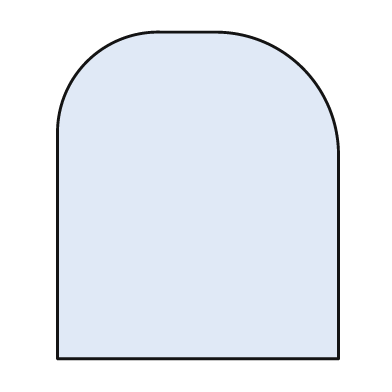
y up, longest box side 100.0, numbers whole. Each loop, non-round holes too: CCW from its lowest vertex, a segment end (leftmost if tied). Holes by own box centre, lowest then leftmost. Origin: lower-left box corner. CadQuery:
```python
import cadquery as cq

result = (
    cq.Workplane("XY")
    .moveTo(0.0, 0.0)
    .lineTo(86.0, 0.0)
    .lineTo(86.0, 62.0)
    .threePointArc((75.0, 89.0), (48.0, 100.0))
    .lineTo(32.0, 100.0)
    .threePointArc((9.0, 91.0), (0.0, 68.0))
    .close()
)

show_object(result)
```